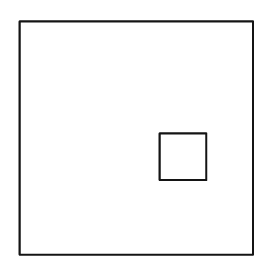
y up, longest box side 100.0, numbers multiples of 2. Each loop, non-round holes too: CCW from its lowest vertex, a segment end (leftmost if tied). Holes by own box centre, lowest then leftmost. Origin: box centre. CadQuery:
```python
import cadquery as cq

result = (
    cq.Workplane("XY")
    .moveTo(-50.0, -50.0)
    .lineTo(50.0, -50.0)
    .lineTo(50.0, 50.0)
    .lineTo(-50.0, 50.0)
    .close()
    .moveTo(10.0, -18.0)
    .lineTo(30.0, -18.0)
    .lineTo(30.0, 2.0)
    .lineTo(10.0, 2.0)
    .close()
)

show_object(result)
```